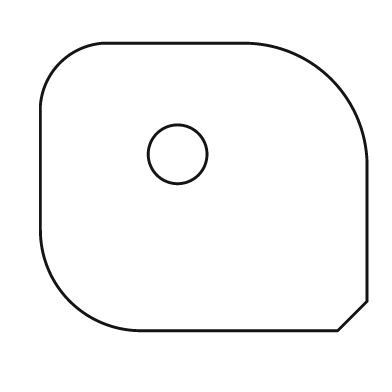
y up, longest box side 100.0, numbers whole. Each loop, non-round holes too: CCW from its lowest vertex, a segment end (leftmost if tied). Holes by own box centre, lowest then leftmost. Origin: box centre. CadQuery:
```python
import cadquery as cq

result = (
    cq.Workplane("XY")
    .moveTo(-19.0, -44.0)
    .lineTo(41.0, -44.0)
    .lineTo(50.0, -35.0)
    .lineTo(50.0, 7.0)
    .threePointArc((39.0, 33.0), (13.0, 44.0))
    .lineTo(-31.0, 44.0)
    .threePointArc((-44.0, 38.0), (-50.0, 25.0))
    .lineTo(-50.0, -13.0)
    .threePointArc((-41.0, -35.0), (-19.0, -44.0))
    .close()
    .moveTo(-8.0, 10.0)
    .circle(9.0)
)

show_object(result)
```